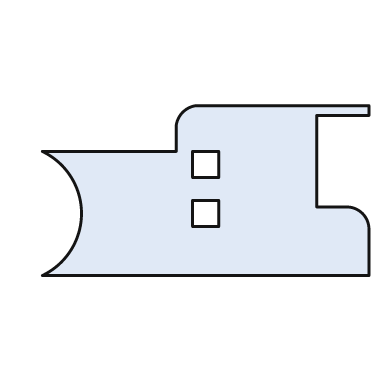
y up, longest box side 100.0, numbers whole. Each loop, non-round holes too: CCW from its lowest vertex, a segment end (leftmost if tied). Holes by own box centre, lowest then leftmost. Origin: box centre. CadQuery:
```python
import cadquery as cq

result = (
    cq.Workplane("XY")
    .moveTo(-50.0, -26.0)
    .lineTo(50.0, -26.0)
    .lineTo(50.0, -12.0)
    .threePointArc((48.0, -7.0), (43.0, -5.0))
    .lineTo(34.0, -5.0)
    .lineTo(34.0, 23.0)
    .lineTo(50.0, 23.0)
    .lineTo(50.0, 26.0)
    .lineTo(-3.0, 26.0)
    .threePointArc((-7.0, 24.0), (-9.0, 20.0))
    .lineTo(-9.0, 12.0)
    .lineTo(-50.0, 12.0)
    .threePointArc((-38.0, -7.0), (-50.0, -26.0))
    .close()
    .moveTo(-4.0, -11.0)
    .lineTo(4.0, -11.0)
    .lineTo(4.0, -3.0)
    .lineTo(-4.0, -3.0)
    .close()
    .moveTo(-4.0, 4.0)
    .lineTo(4.0, 4.0)
    .lineTo(4.0, 12.0)
    .lineTo(-4.0, 12.0)
    .close()
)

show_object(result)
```